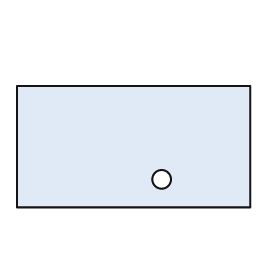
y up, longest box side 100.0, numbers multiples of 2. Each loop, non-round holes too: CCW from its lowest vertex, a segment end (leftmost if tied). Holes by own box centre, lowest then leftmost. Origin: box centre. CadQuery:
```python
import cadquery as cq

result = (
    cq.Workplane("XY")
    .moveTo(-50.0, -26.0)
    .lineTo(50.0, -26.0)
    .lineTo(50.0, 26.0)
    .lineTo(-50.0, 26.0)
    .close()
    .moveTo(12.0, -14.0)
    .circle(4.0)
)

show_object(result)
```